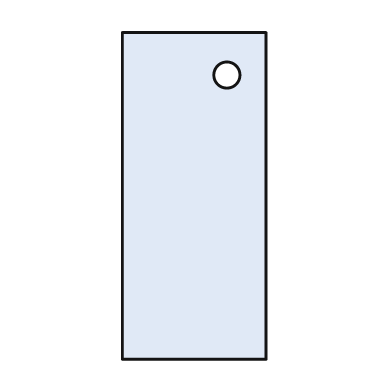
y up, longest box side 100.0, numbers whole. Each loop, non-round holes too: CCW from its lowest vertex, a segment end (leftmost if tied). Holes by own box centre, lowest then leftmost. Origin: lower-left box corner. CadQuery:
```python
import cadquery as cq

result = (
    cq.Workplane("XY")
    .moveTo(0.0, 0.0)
    .lineTo(44.0, 0.0)
    .lineTo(44.0, 100.0)
    .lineTo(0.0, 100.0)
    .close()
    .moveTo(32.0, 87.0)
    .circle(4.0)
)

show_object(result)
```